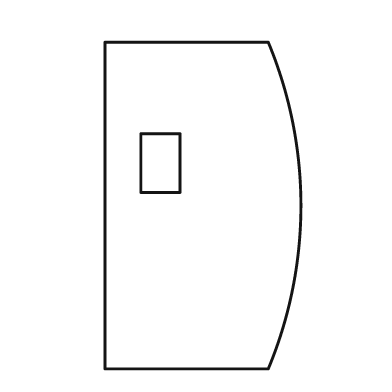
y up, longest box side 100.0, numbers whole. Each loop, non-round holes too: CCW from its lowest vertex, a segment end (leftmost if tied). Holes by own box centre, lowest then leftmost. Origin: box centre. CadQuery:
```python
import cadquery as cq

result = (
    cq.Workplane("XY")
    .moveTo(-30.0, -50.0)
    .lineTo(20.0, -50.0)
    .threePointArc((30.0, 0.0), (20.0, 50.0))
    .lineTo(-30.0, 50.0)
    .close()
    .moveTo(-19.0, 4.0)
    .lineTo(-7.0, 4.0)
    .lineTo(-7.0, 22.0)
    .lineTo(-19.0, 22.0)
    .close()
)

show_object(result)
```